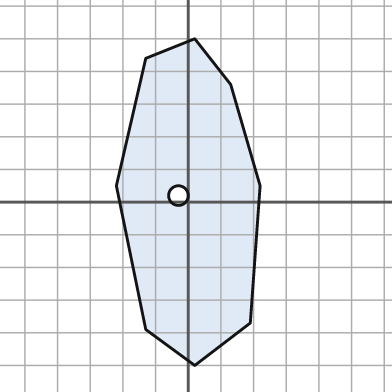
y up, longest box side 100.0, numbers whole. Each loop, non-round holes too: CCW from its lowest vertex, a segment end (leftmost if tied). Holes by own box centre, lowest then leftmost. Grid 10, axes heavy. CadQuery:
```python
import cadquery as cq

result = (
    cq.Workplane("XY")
    .moveTo(2.0, -50.0)
    .lineTo(19.0, -37.0)
    .lineTo(22.0, 5.0)
    .lineTo(13.0, 36.0)
    .lineTo(2.0, 50.0)
    .lineTo(-13.0, 44.0)
    .lineTo(-22.0, 5.0)
    .lineTo(-13.0, -39.0)
    .close()
    .moveTo(-3.0, 2.0)
    .circle(3.0)
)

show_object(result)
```